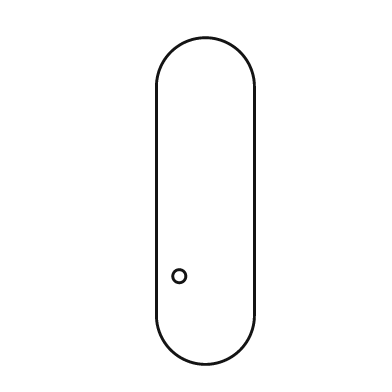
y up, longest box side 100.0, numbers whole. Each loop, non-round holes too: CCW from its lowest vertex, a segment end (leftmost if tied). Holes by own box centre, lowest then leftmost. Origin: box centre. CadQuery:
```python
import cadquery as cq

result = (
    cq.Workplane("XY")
    .moveTo(-15.0, -35.0)
    .threePointArc((0.0, -50.0), (15.0, -35.0))
    .lineTo(15.0, 35.0)
    .threePointArc((0.0, 50.0), (-15.0, 35.0))
    .close()
    .moveTo(-8.0, -23.0)
    .circle(2.0)
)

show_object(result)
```